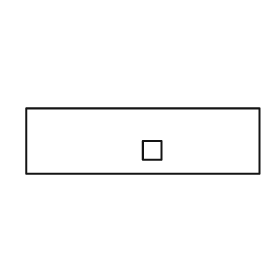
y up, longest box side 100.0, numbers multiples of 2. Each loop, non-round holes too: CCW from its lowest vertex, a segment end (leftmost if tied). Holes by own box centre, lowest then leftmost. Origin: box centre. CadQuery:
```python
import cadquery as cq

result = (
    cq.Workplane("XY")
    .moveTo(-50.0, -14.0)
    .lineTo(50.0, -14.0)
    .lineTo(50.0, 14.0)
    .lineTo(-50.0, 14.0)
    .close()
    .moveTo(0.0, -8.0)
    .lineTo(8.0, -8.0)
    .lineTo(8.0, 0.0)
    .lineTo(0.0, 0.0)
    .close()
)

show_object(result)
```